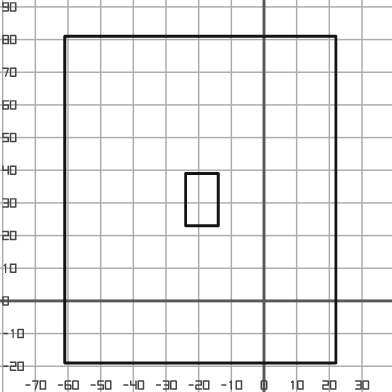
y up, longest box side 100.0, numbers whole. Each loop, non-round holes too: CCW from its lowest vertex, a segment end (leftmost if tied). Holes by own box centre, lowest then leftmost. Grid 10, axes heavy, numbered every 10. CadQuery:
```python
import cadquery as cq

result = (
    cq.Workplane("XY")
    .moveTo(-61.0, -19.0)
    .lineTo(22.0, -19.0)
    .lineTo(22.0, 81.0)
    .lineTo(-61.0, 81.0)
    .close()
    .moveTo(-24.0, 23.0)
    .lineTo(-14.0, 23.0)
    .lineTo(-14.0, 39.0)
    .lineTo(-24.0, 39.0)
    .close()
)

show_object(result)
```